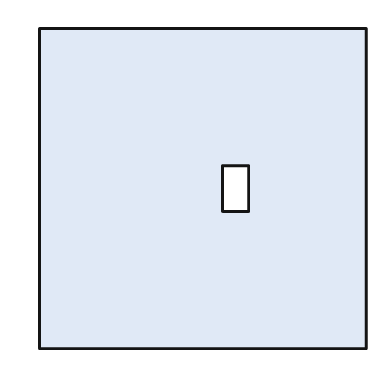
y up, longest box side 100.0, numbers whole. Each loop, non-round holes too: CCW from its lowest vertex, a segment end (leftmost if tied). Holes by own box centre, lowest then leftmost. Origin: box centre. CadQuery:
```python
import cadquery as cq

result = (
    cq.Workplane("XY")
    .moveTo(-50.0, -49.0)
    .lineTo(50.0, -49.0)
    .lineTo(50.0, 49.0)
    .lineTo(-50.0, 49.0)
    .close()
    .moveTo(6.0, -7.0)
    .lineTo(14.0, -7.0)
    .lineTo(14.0, 7.0)
    .lineTo(6.0, 7.0)
    .close()
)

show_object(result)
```